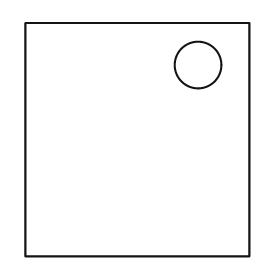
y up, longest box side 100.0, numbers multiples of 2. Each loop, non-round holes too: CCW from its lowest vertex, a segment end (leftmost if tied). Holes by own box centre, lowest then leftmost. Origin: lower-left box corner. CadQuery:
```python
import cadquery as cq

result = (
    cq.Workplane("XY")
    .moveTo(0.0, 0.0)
    .lineTo(96.0, 0.0)
    .lineTo(96.0, 100.0)
    .lineTo(0.0, 100.0)
    .close()
    .moveTo(74.0, 82.0)
    .circle(10.0)
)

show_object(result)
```